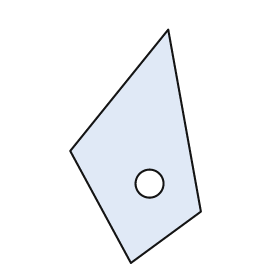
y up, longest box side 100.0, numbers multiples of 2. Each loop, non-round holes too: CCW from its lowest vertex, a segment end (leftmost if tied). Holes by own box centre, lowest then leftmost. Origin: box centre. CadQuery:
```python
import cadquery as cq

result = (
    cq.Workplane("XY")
    .moveTo(-2.0, -50.0)
    .lineTo(28.0, -28.0)
    .lineTo(14.0, 50.0)
    .lineTo(-28.0, -2.0)
    .close()
    .moveTo(6.0, -16.0)
    .circle(6.0)
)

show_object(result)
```